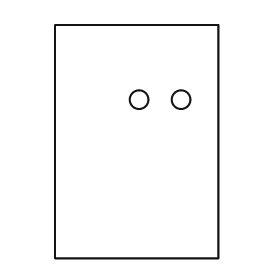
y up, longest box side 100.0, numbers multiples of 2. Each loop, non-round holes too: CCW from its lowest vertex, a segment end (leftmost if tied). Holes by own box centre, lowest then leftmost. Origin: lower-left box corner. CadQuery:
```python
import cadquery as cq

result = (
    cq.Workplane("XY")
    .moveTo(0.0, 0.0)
    .lineTo(70.0, 0.0)
    .lineTo(70.0, 100.0)
    .lineTo(0.0, 100.0)
    .close()
    .moveTo(36.0, 68.0)
    .circle(4.0)
    .moveTo(54.0, 68.0)
    .circle(4.0)
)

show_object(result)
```